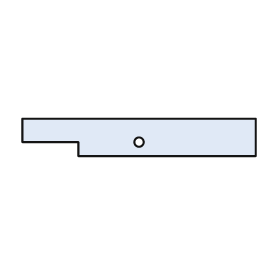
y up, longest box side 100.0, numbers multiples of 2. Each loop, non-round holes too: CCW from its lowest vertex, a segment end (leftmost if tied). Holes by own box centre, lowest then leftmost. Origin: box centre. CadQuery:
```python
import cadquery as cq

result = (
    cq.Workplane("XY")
    .moveTo(-26.0, -8.0)
    .lineTo(50.0, -8.0)
    .lineTo(50.0, 8.0)
    .lineTo(-50.0, 8.0)
    .lineTo(-50.0, -2.0)
    .lineTo(-26.0, -2.0)
    .close()
    .moveTo(0.0, -2.0)
    .circle(2.0)
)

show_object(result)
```